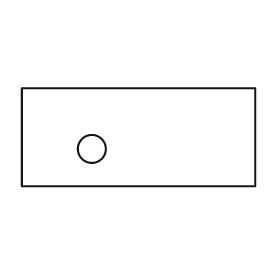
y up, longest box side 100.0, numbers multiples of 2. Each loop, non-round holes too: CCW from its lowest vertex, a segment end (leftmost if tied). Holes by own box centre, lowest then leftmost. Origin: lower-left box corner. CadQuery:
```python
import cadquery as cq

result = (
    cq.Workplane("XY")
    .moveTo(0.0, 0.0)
    .lineTo(100.0, 0.0)
    .lineTo(100.0, 42.0)
    .lineTo(0.0, 42.0)
    .close()
    .moveTo(30.0, 16.0)
    .circle(6.0)
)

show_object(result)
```